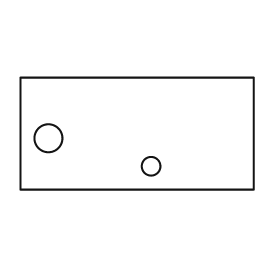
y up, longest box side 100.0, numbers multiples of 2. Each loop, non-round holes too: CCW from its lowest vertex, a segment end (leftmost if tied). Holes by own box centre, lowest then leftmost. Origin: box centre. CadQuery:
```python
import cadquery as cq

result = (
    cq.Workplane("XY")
    .moveTo(-50.0, -24.0)
    .lineTo(50.0, -24.0)
    .lineTo(50.0, 24.0)
    .lineTo(-50.0, 24.0)
    .close()
    .moveTo(6.0, -14.0)
    .circle(4.0)
    .moveTo(-38.0, -2.0)
    .circle(6.0)
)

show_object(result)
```